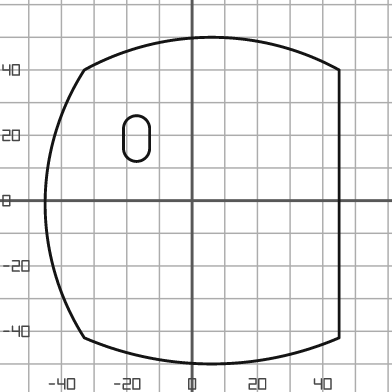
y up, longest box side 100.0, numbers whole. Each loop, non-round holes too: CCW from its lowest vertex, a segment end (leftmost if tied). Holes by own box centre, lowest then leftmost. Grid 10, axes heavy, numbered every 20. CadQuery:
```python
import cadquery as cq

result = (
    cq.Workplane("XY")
    .moveTo(-33.0, -42.0)
    .threePointArc((6.0, -50.0), (45.0, -42.0))
    .lineTo(45.0, 40.0)
    .threePointArc((6.0, 50.0), (-33.0, 40.0))
    .threePointArc((-45.0, -1.0), (-33.0, -42.0))
    .close()
    .moveTo(-21.0, 16.0)
    .threePointArc((-17.0, 12.0), (-13.0, 16.0))
    .lineTo(-13.0, 22.0)
    .threePointArc((-17.0, 26.0), (-21.0, 22.0))
    .close()
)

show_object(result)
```